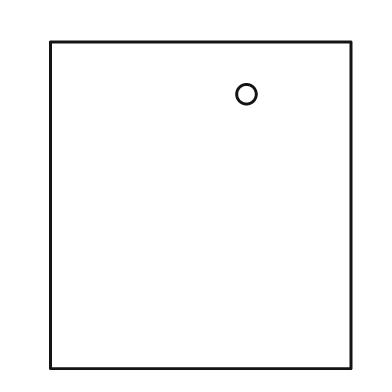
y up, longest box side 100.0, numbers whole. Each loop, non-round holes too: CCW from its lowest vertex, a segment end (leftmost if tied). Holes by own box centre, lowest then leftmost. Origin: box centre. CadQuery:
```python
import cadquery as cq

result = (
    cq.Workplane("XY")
    .moveTo(-46.0, -50.0)
    .lineTo(46.0, -50.0)
    .lineTo(46.0, 50.0)
    .lineTo(-46.0, 50.0)
    .close()
    .moveTo(14.0, 34.0)
    .circle(3.0)
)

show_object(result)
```